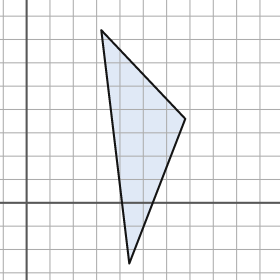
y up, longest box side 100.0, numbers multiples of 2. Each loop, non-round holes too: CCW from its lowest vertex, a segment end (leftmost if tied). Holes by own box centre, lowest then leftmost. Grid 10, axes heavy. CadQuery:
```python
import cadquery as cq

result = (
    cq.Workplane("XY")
    .moveTo(44.0, -26.0)
    .lineTo(68.0, 36.0)
    .lineTo(32.0, 74.0)
    .close()
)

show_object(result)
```